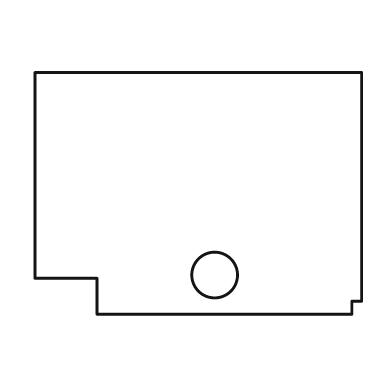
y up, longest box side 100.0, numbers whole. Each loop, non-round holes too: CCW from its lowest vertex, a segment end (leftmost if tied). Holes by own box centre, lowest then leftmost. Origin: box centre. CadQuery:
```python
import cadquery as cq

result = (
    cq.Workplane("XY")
    .moveTo(-31.0, -37.0)
    .lineTo(47.0, -37.0)
    .lineTo(47.0, -33.0)
    .lineTo(50.0, -33.0)
    .lineTo(50.0, 37.0)
    .lineTo(-50.0, 37.0)
    .lineTo(-50.0, -26.0)
    .lineTo(-31.0, -26.0)
    .close()
    .moveTo(5.0, -25.0)
    .circle(7.0)
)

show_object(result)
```